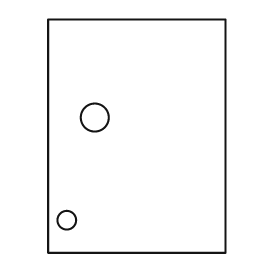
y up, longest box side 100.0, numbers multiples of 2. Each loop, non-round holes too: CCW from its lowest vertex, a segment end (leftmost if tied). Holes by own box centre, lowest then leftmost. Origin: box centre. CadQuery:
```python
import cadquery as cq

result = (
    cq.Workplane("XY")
    .moveTo(-38.0, -50.0)
    .lineTo(38.0, -50.0)
    .lineTo(38.0, 50.0)
    .lineTo(-38.0, 50.0)
    .close()
    .moveTo(-30.0, -36.0)
    .circle(4.0)
    .moveTo(-18.0, 8.0)
    .circle(6.0)
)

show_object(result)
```